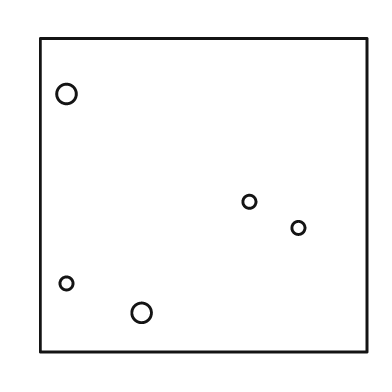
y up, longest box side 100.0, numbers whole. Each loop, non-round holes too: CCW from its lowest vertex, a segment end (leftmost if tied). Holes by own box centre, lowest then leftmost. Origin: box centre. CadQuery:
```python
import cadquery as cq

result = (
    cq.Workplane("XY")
    .moveTo(-50.0, -48.0)
    .lineTo(50.0, -48.0)
    .lineTo(50.0, 48.0)
    .lineTo(-50.0, 48.0)
    .close()
    .moveTo(-19.0, -36.0)
    .circle(3.0)
    .moveTo(-42.0, -27.0)
    .circle(2.0)
    .moveTo(29.0, -10.0)
    .circle(2.0)
    .moveTo(14.0, -2.0)
    .circle(2.0)
    .moveTo(-42.0, 31.0)
    .circle(3.0)
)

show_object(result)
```